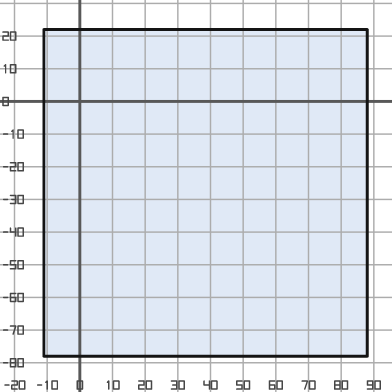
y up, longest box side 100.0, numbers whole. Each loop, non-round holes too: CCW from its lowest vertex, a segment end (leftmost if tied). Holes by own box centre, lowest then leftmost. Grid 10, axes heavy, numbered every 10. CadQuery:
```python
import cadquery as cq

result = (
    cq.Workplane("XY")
    .moveTo(-11.0, -78.0)
    .lineTo(88.0, -78.0)
    .lineTo(88.0, 22.0)
    .lineTo(-11.0, 22.0)
    .close()
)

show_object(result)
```